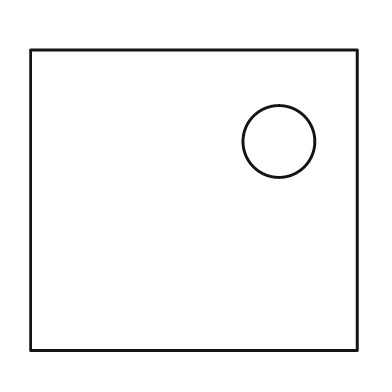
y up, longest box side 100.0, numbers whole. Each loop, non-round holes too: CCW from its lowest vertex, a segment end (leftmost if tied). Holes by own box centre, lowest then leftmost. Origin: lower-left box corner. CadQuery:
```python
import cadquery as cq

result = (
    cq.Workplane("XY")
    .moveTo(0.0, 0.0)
    .lineTo(100.0, 0.0)
    .lineTo(100.0, 92.0)
    .lineTo(0.0, 92.0)
    .close()
    .moveTo(76.0, 64.0)
    .circle(11.0)
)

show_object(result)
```